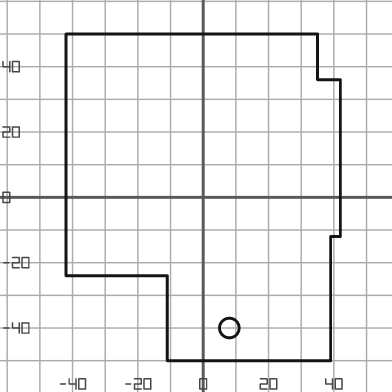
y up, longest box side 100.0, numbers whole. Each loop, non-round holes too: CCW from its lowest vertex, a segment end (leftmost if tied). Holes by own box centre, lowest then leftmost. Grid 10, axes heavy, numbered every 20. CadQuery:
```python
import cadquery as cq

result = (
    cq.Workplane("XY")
    .moveTo(-11.0, -50.0)
    .lineTo(39.0, -50.0)
    .lineTo(39.0, -12.0)
    .lineTo(42.0, -12.0)
    .lineTo(42.0, 36.0)
    .lineTo(35.0, 36.0)
    .lineTo(35.0, 50.0)
    .lineTo(-42.0, 50.0)
    .lineTo(-42.0, -24.0)
    .lineTo(-11.0, -24.0)
    .close()
    .moveTo(8.0, -40.0)
    .circle(3.0)
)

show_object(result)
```